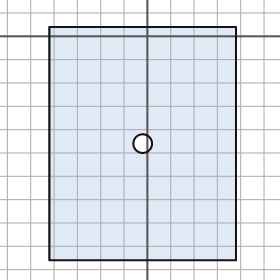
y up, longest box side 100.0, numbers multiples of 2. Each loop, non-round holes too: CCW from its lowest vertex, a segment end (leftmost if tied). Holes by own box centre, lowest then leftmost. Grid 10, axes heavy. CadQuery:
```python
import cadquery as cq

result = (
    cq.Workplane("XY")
    .moveTo(-42.0, -96.0)
    .lineTo(38.0, -96.0)
    .lineTo(38.0, 4.0)
    .lineTo(-42.0, 4.0)
    .close()
    .moveTo(-2.0, -46.0)
    .circle(4.0)
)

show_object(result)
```